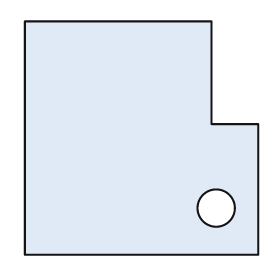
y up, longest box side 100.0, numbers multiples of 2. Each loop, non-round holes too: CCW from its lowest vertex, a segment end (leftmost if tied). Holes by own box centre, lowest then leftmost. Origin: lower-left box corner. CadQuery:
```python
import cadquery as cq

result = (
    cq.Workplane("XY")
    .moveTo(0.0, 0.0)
    .lineTo(100.0, 0.0)
    .lineTo(100.0, 56.0)
    .lineTo(80.0, 56.0)
    .lineTo(80.0, 100.0)
    .lineTo(0.0, 100.0)
    .close()
    .moveTo(82.0, 20.0)
    .circle(8.0)
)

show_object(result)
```